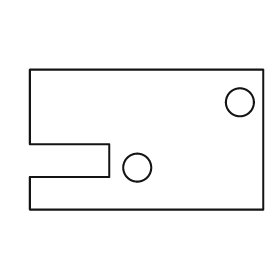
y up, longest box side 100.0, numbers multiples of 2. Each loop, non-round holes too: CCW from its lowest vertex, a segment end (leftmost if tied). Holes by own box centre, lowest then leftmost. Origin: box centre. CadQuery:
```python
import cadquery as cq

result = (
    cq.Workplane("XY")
    .moveTo(-50.0, -30.0)
    .lineTo(50.0, -30.0)
    .lineTo(50.0, 30.0)
    .lineTo(-50.0, 30.0)
    .lineTo(-50.0, -2.0)
    .lineTo(-16.0, -2.0)
    .lineTo(-16.0, -16.0)
    .lineTo(-50.0, -16.0)
    .close()
    .moveTo(-4.0, -12.0)
    .circle(6.0)
    .moveTo(40.0, 16.0)
    .circle(6.0)
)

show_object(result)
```